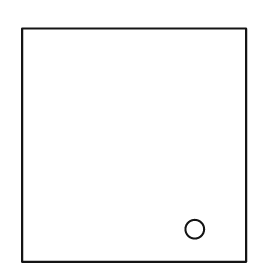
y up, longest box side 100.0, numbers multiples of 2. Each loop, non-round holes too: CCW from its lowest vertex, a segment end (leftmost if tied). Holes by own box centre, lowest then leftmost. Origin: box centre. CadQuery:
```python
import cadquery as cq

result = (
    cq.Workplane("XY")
    .moveTo(-48.0, -50.0)
    .lineTo(48.0, -50.0)
    .lineTo(48.0, 50.0)
    .lineTo(-48.0, 50.0)
    .close()
    .moveTo(26.0, -36.0)
    .circle(4.0)
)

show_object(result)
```